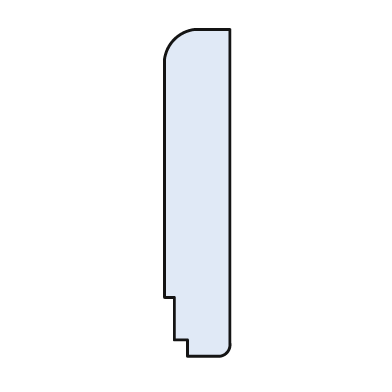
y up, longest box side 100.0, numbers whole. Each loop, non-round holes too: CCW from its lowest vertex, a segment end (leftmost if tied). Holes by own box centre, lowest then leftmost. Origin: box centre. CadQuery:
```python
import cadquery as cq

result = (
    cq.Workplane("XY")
    .moveTo(-3.0, -50.0)
    .lineTo(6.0, -50.0)
    .threePointArc((9.0, -49.0), (10.0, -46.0))
    .lineTo(10.0, 50.0)
    .lineTo(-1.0, 50.0)
    .threePointArc((-7.0, 47.0), (-10.0, 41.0))
    .lineTo(-10.0, -32.0)
    .lineTo(-7.0, -32.0)
    .lineTo(-7.0, -45.0)
    .lineTo(-3.0, -45.0)
    .close()
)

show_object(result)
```